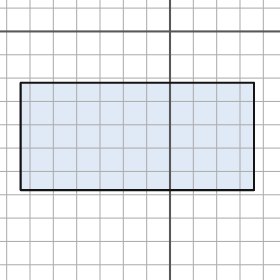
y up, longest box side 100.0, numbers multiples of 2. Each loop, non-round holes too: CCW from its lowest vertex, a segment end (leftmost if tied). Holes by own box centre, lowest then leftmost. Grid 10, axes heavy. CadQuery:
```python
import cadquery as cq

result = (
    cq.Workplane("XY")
    .moveTo(-64.0, -68.0)
    .lineTo(36.0, -68.0)
    .lineTo(36.0, -22.0)
    .lineTo(-64.0, -22.0)
    .close()
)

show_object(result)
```